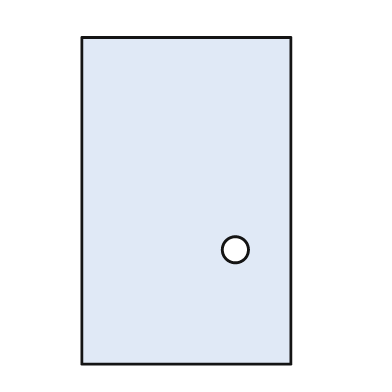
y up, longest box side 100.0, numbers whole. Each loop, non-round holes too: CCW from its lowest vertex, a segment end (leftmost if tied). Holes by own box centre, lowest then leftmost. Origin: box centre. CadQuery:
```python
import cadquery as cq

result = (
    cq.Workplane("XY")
    .moveTo(-32.0, -50.0)
    .lineTo(32.0, -50.0)
    .lineTo(32.0, 50.0)
    .lineTo(-32.0, 50.0)
    .close()
    .moveTo(15.0, -15.0)
    .circle(4.0)
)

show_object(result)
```